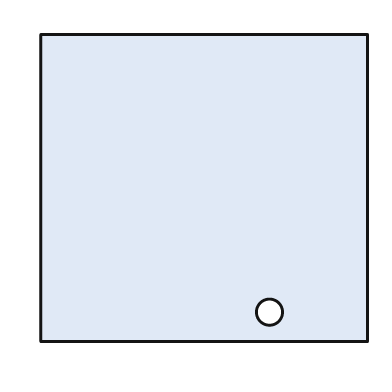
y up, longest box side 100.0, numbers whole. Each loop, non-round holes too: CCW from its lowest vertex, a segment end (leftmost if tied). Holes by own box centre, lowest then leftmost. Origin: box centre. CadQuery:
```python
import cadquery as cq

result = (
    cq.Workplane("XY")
    .moveTo(-50.0, -47.0)
    .lineTo(50.0, -47.0)
    .lineTo(50.0, 47.0)
    .lineTo(-50.0, 47.0)
    .close()
    .moveTo(20.0, -38.0)
    .circle(4.0)
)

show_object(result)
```